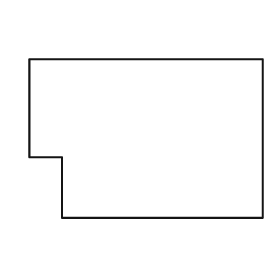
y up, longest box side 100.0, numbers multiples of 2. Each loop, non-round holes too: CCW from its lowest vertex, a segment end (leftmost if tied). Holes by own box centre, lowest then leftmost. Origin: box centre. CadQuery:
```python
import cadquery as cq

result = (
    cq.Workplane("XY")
    .moveTo(-36.0, -34.0)
    .lineTo(50.0, -34.0)
    .lineTo(50.0, 34.0)
    .lineTo(-50.0, 34.0)
    .lineTo(-50.0, -8.0)
    .lineTo(-36.0, -8.0)
    .close()
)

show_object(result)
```